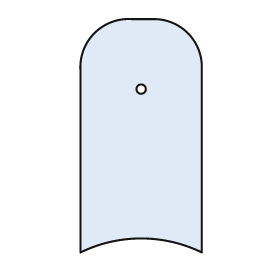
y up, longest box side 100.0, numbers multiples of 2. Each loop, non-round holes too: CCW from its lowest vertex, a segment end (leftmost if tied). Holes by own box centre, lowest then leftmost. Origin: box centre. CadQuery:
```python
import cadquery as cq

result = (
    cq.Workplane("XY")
    .moveTo(-26.0, -50.0)
    .threePointArc((0.0, -44.0), (26.0, -50.0))
    .lineTo(26.0, 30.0)
    .threePointArc((20.0, 44.0), (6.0, 50.0))
    .lineTo(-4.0, 50.0)
    .threePointArc((-20.0, 44.0), (-26.0, 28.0))
    .close()
    .moveTo(0.0, 20.0)
    .circle(2.0)
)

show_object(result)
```